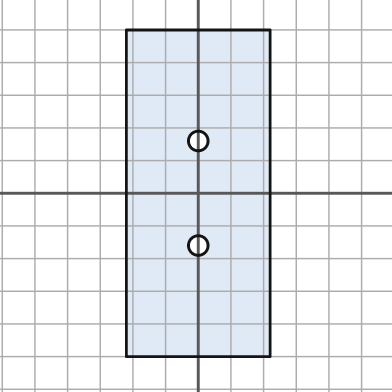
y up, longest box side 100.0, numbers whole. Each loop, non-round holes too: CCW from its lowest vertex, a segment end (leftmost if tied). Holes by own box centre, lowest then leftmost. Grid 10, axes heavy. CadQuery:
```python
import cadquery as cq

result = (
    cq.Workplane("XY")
    .moveTo(-22.0, -50.0)
    .lineTo(22.0, -50.0)
    .lineTo(22.0, 50.0)
    .lineTo(-22.0, 50.0)
    .close()
    .moveTo(0.0, -16.0)
    .circle(3.0)
    .moveTo(0.0, 16.0)
    .circle(3.0)
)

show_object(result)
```